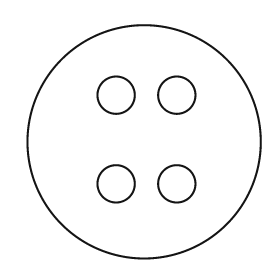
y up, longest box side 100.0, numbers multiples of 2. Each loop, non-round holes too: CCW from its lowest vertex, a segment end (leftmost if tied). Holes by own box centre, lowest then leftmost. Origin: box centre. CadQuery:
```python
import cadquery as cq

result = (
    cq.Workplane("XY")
    .moveTo(0.0, 0.0)
    .circle(50.0)
    .moveTo(-12.0, -18.0)
    .circle(8.0)
    .moveTo(14.0, -18.0)
    .circle(8.0)
    .moveTo(-12.0, 20.0)
    .circle(8.0)
    .moveTo(14.0, 20.0)
    .circle(8.0)
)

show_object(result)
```